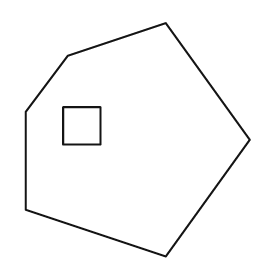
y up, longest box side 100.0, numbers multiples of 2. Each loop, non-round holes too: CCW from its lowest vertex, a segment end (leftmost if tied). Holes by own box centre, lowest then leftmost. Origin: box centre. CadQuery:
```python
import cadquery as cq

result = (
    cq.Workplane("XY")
    .moveTo(12.0, -50.0)
    .lineTo(48.0, 0.0)
    .lineTo(12.0, 50.0)
    .lineTo(-30.0, 36.0)
    .lineTo(-48.0, 12.0)
    .lineTo(-48.0, -30.0)
    .close()
    .moveTo(-32.0, -2.0)
    .lineTo(-16.0, -2.0)
    .lineTo(-16.0, 14.0)
    .lineTo(-32.0, 14.0)
    .close()
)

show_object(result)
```